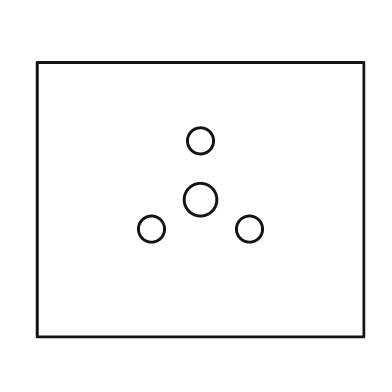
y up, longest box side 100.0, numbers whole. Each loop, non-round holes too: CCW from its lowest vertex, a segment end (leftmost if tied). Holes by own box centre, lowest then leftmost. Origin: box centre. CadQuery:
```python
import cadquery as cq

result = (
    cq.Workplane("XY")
    .moveTo(-50.0, -42.0)
    .lineTo(50.0, -42.0)
    .lineTo(50.0, 42.0)
    .lineTo(-50.0, 42.0)
    .close()
    .moveTo(-15.0, -9.0)
    .circle(4.0)
    .moveTo(15.0, -9.0)
    .circle(4.0)
    .moveTo(0.0, 0.0)
    .circle(5.0)
    .moveTo(0.0, 18.0)
    .circle(4.0)
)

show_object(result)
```